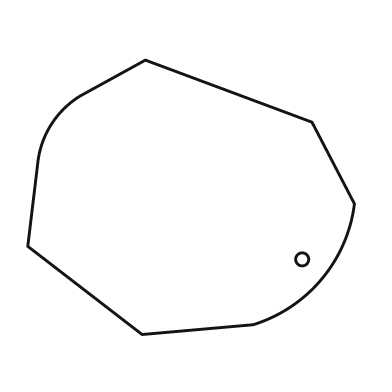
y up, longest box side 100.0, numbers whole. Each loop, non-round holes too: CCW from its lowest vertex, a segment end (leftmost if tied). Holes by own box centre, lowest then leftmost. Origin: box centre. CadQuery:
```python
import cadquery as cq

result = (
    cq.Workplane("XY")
    .moveTo(-15.0, -42.0)
    .lineTo(19.0, -39.0)
    .threePointArc((40.0, -25.0), (50.0, -2.0))
    .lineTo(37.0, 23.0)
    .lineTo(-14.0, 42.0)
    .lineTo(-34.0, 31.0)
    .threePointArc((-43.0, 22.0), (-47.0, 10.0))
    .lineTo(-50.0, -15.0)
    .close()
    .moveTo(34.0, -19.0)
    .circle(2.0)
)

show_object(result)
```